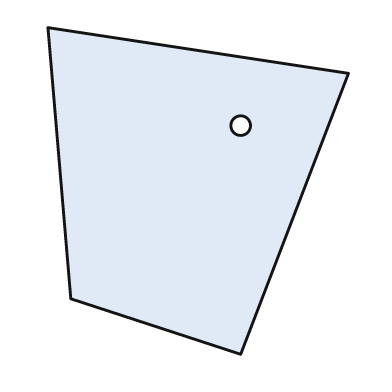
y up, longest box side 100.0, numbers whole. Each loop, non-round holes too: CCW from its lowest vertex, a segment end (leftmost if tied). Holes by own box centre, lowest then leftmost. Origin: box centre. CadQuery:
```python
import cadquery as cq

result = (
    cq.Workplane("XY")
    .moveTo(13.0, -50.0)
    .lineTo(46.0, 36.0)
    .lineTo(-46.0, 50.0)
    .lineTo(-39.0, -33.0)
    .close()
    .moveTo(13.0, 20.0)
    .circle(3.0)
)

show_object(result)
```